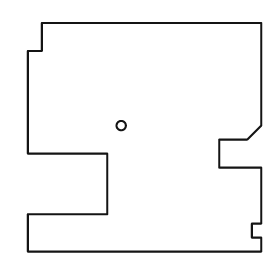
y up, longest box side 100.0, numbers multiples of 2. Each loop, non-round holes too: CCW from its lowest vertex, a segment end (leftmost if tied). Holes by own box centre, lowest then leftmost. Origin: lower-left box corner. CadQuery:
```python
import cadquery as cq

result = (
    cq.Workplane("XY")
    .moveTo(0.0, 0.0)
    .lineTo(100.0, 0.0)
    .lineTo(100.0, 6.0)
    .lineTo(96.0, 6.0)
    .lineTo(96.0, 12.0)
    .lineTo(100.0, 12.0)
    .lineTo(100.0, 36.0)
    .lineTo(82.0, 36.0)
    .lineTo(82.0, 48.0)
    .lineTo(94.0, 48.0)
    .lineTo(100.0, 54.0)
    .lineTo(100.0, 98.0)
    .lineTo(6.0, 98.0)
    .lineTo(6.0, 86.0)
    .lineTo(0.0, 86.0)
    .lineTo(0.0, 42.0)
    .lineTo(34.0, 42.0)
    .lineTo(34.0, 16.0)
    .lineTo(0.0, 16.0)
    .close()
    .moveTo(40.0, 54.0)
    .circle(2.0)
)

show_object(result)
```